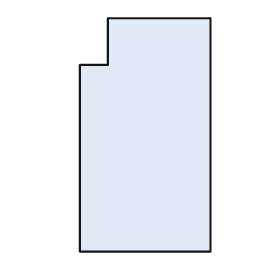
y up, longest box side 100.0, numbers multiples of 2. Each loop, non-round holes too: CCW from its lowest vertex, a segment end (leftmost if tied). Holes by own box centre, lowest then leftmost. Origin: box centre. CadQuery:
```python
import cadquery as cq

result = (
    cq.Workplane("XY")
    .moveTo(-28.0, -50.0)
    .lineTo(28.0, -50.0)
    .lineTo(28.0, 50.0)
    .lineTo(-16.0, 50.0)
    .lineTo(-16.0, 30.0)
    .lineTo(-28.0, 30.0)
    .close()
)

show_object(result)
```